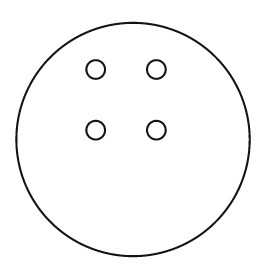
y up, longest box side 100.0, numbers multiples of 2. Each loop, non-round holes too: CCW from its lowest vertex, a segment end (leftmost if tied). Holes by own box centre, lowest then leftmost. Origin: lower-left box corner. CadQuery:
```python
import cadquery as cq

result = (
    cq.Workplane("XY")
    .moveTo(50.0, 50.0)
    .circle(50.0)
    .moveTo(34.0, 54.0)
    .circle(4.0)
    .moveTo(60.0, 54.0)
    .circle(4.0)
    .moveTo(34.0, 80.0)
    .circle(4.0)
    .moveTo(60.0, 80.0)
    .circle(4.0)
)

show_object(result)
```